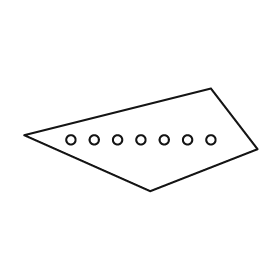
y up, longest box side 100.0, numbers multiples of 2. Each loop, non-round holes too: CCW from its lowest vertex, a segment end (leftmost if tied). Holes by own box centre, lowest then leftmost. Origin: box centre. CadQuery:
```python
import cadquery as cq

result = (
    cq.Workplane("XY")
    .moveTo(4.0, -22.0)
    .lineTo(50.0, -4.0)
    .lineTo(30.0, 22.0)
    .lineTo(-50.0, 2.0)
    .close()
    .moveTo(-30.0, 0.0)
    .circle(2.0)
    .moveTo(-20.0, 0.0)
    .circle(2.0)
    .moveTo(-10.0, 0.0)
    .circle(2.0)
    .moveTo(0.0, 0.0)
    .circle(2.0)
    .moveTo(10.0, 0.0)
    .circle(2.0)
    .moveTo(20.0, 0.0)
    .circle(2.0)
    .moveTo(30.0, 0.0)
    .circle(2.0)
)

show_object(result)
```